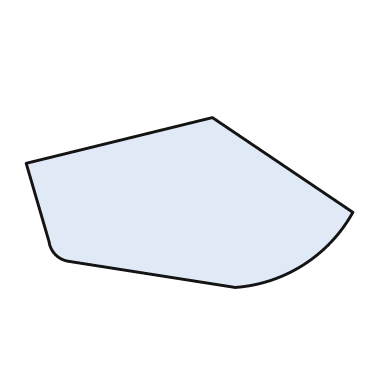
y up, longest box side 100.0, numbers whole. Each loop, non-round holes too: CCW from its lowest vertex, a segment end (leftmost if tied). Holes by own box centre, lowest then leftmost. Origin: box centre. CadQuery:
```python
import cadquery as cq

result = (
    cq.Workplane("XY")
    .moveTo(14.0, -26.0)
    .threePointArc((35.0, -19.0), (50.0, -3.0))
    .lineTo(7.0, 26.0)
    .lineTo(-50.0, 12.0)
    .lineTo(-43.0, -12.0)
    .threePointArc((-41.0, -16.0), (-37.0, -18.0))
    .close()
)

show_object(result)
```